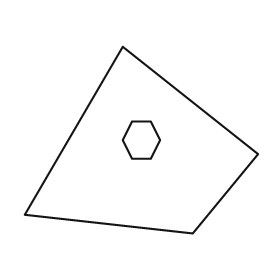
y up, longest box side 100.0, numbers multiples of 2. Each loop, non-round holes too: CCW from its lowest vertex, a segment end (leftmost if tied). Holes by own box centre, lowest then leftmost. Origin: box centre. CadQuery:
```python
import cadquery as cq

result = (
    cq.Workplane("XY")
    .moveTo(22.0, -40.0)
    .lineTo(50.0, -6.0)
    .lineTo(-8.0, 40.0)
    .lineTo(-50.0, -32.0)
    .close()
    .moveTo(-4.0, -8.0)
    .lineTo(4.0, -8.0)
    .lineTo(8.0, 0.0)
    .lineTo(4.0, 8.0)
    .lineTo(-4.0, 8.0)
    .lineTo(-8.0, 0.0)
    .close()
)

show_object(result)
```